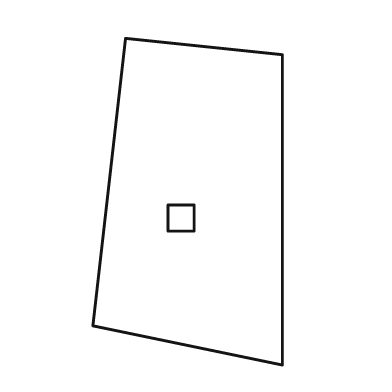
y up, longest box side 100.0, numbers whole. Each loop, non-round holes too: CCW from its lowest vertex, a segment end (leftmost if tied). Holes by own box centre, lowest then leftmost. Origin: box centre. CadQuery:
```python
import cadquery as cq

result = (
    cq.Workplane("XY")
    .moveTo(29.0, -50.0)
    .lineTo(29.0, 45.0)
    .lineTo(-19.0, 50.0)
    .lineTo(-29.0, -38.0)
    .close()
    .moveTo(-6.0, -9.0)
    .lineTo(2.0, -9.0)
    .lineTo(2.0, -1.0)
    .lineTo(-6.0, -1.0)
    .close()
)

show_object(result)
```